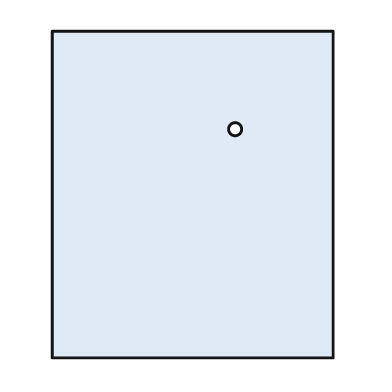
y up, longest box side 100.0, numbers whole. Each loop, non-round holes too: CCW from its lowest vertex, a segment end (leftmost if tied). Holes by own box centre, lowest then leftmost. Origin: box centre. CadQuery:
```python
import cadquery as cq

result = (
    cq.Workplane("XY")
    .moveTo(-43.0, -50.0)
    .lineTo(43.0, -50.0)
    .lineTo(43.0, 50.0)
    .lineTo(-43.0, 50.0)
    .close()
    .moveTo(13.0, 20.0)
    .circle(2.0)
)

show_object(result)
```